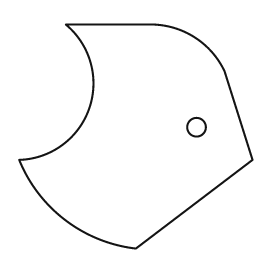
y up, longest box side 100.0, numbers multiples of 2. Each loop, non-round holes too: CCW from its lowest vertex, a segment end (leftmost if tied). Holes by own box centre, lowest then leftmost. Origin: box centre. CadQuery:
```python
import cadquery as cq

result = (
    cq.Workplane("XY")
    .moveTo(0.0, -48.0)
    .lineTo(50.0, -10.0)
    .lineTo(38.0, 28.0)
    .threePointArc((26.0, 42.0), (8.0, 48.0))
    .lineTo(-30.0, 48.0)
    .threePointArc((-20.0, 12.0), (-50.0, -10.0))
    .threePointArc((-30.0, -36.0), (0.0, -48.0))
    .close()
    .moveTo(26.0, 4.0)
    .circle(4.0)
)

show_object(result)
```